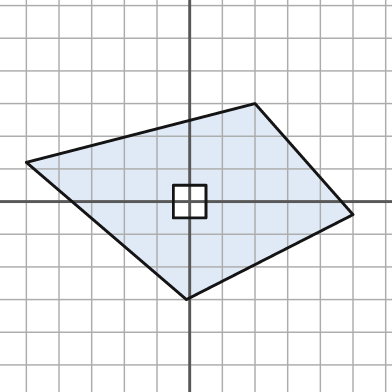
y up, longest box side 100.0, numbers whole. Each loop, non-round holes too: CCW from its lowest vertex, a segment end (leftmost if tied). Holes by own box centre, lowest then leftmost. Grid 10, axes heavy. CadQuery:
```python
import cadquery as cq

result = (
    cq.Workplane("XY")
    .moveTo(-1.0, -30.0)
    .lineTo(50.0, -4.0)
    .lineTo(20.0, 30.0)
    .lineTo(-50.0, 12.0)
    .close()
    .moveTo(-5.0, -5.0)
    .lineTo(5.0, -5.0)
    .lineTo(5.0, 5.0)
    .lineTo(-5.0, 5.0)
    .close()
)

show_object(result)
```